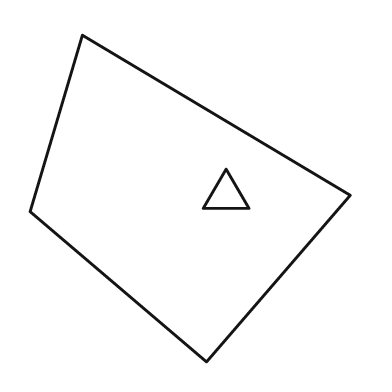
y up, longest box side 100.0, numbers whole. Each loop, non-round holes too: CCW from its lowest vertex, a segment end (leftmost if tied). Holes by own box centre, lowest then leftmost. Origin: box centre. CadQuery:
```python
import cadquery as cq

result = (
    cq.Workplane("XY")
    .moveTo(5.0, -50.0)
    .lineTo(49.0, 1.0)
    .lineTo(-33.0, 50.0)
    .lineTo(-49.0, -4.0)
    .close()
    .moveTo(4.0, -3.0)
    .lineTo(18.0, -3.0)
    .lineTo(11.0, 9.0)
    .close()
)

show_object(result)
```